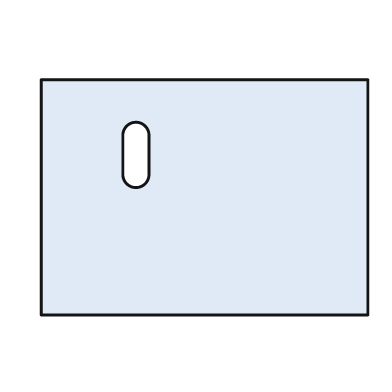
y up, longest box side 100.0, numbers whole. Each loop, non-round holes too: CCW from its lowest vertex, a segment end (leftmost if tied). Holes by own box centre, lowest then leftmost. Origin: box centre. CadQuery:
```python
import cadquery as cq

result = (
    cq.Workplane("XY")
    .moveTo(-50.0, -36.0)
    .lineTo(50.0, -36.0)
    .lineTo(50.0, 36.0)
    .lineTo(-50.0, 36.0)
    .close()
    .moveTo(-25.0, 7.0)
    .threePointArc((-21.0, 3.0), (-17.0, 7.0))
    .lineTo(-17.0, 19.0)
    .threePointArc((-21.0, 23.0), (-25.0, 19.0))
    .close()
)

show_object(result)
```